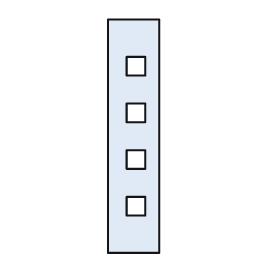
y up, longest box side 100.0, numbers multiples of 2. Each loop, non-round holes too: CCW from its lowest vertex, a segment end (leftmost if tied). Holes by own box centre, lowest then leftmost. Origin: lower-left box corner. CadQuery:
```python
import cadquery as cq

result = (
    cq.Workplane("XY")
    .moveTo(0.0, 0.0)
    .lineTo(22.0, 0.0)
    .lineTo(22.0, 100.0)
    .lineTo(0.0, 100.0)
    .close()
    .moveTo(8.0, 16.0)
    .lineTo(16.0, 16.0)
    .lineTo(16.0, 24.0)
    .lineTo(8.0, 24.0)
    .close()
    .moveTo(8.0, 36.0)
    .lineTo(16.0, 36.0)
    .lineTo(16.0, 44.0)
    .lineTo(8.0, 44.0)
    .close()
    .moveTo(8.0, 56.0)
    .lineTo(16.0, 56.0)
    .lineTo(16.0, 64.0)
    .lineTo(8.0, 64.0)
    .close()
    .moveTo(8.0, 76.0)
    .lineTo(16.0, 76.0)
    .lineTo(16.0, 84.0)
    .lineTo(8.0, 84.0)
    .close()
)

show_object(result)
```